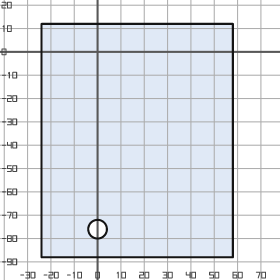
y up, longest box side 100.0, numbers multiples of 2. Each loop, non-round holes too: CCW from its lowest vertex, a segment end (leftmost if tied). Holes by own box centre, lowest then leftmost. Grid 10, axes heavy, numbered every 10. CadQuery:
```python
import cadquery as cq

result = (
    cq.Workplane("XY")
    .moveTo(-24.0, -88.0)
    .lineTo(58.0, -88.0)
    .lineTo(58.0, 12.0)
    .lineTo(-24.0, 12.0)
    .close()
    .moveTo(0.0, -76.0)
    .circle(4.0)
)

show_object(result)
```